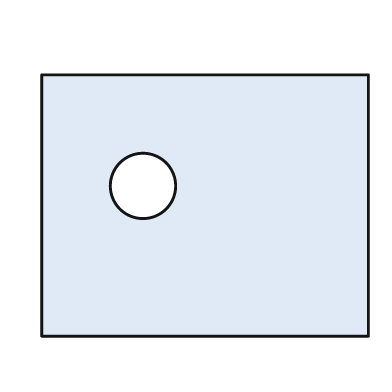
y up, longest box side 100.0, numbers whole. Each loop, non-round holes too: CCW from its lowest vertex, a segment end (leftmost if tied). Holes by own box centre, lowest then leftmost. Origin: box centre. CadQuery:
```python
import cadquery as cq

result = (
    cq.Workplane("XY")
    .moveTo(-50.0, -40.0)
    .lineTo(50.0, -40.0)
    .lineTo(50.0, 40.0)
    .lineTo(-50.0, 40.0)
    .close()
    .moveTo(-19.0, 6.0)
    .circle(10.0)
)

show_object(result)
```